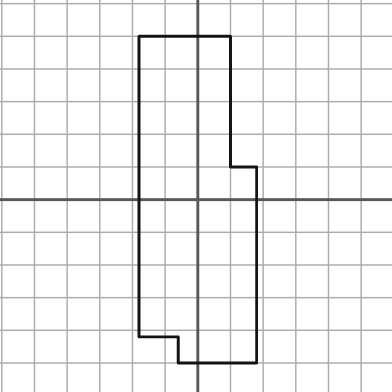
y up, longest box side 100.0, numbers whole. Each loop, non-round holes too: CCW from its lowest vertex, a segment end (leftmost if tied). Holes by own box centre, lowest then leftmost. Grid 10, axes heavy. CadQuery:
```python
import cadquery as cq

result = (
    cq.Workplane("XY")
    .moveTo(-6.0, -50.0)
    .lineTo(18.0, -50.0)
    .lineTo(18.0, 10.0)
    .lineTo(10.0, 10.0)
    .lineTo(10.0, 50.0)
    .lineTo(-18.0, 50.0)
    .lineTo(-18.0, -42.0)
    .lineTo(-6.0, -42.0)
    .close()
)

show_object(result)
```